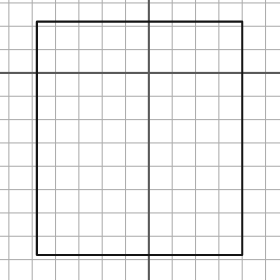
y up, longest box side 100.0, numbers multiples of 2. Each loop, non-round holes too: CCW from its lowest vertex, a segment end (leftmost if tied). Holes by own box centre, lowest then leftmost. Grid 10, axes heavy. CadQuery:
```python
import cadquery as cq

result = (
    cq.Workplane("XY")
    .moveTo(-48.0, -78.0)
    .lineTo(40.0, -78.0)
    .lineTo(40.0, 22.0)
    .lineTo(-48.0, 22.0)
    .close()
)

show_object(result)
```